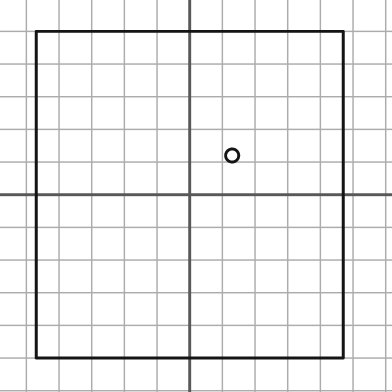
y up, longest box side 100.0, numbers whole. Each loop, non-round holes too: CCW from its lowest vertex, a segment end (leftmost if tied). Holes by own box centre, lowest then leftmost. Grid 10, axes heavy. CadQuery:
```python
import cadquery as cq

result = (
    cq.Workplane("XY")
    .moveTo(-47.0, -50.0)
    .lineTo(47.0, -50.0)
    .lineTo(47.0, 50.0)
    .lineTo(-47.0, 50.0)
    .close()
    .moveTo(13.0, 12.0)
    .circle(2.0)
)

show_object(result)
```